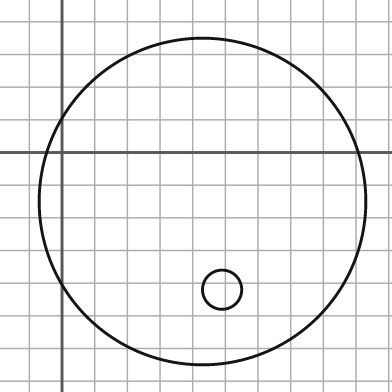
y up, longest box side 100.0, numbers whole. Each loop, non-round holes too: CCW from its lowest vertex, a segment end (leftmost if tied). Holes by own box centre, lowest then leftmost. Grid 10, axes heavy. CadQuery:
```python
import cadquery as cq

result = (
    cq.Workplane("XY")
    .moveTo(43.0, -15.0)
    .circle(50.0)
    .moveTo(49.0, -42.0)
    .circle(6.0)
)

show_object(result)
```